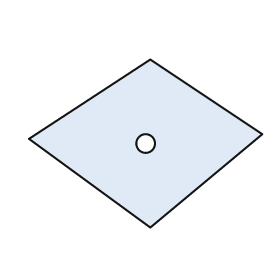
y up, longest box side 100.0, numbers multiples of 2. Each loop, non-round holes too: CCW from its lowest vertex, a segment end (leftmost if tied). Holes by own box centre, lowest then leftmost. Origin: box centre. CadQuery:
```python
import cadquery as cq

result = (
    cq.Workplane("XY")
    .moveTo(2.0, -36.0)
    .lineTo(50.0, 4.0)
    .lineTo(2.0, 36.0)
    .lineTo(-50.0, 2.0)
    .close()
    .moveTo(0.0, 0.0)
    .circle(4.0)
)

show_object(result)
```